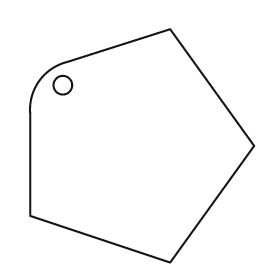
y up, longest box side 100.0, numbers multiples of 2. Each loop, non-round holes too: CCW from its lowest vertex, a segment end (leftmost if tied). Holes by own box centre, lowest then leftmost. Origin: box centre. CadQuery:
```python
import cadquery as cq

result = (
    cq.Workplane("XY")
    .moveTo(12.0, -50.0)
    .lineTo(48.0, 0.0)
    .lineTo(12.0, 50.0)
    .lineTo(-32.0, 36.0)
    .threePointArc((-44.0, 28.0), (-48.0, 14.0))
    .lineTo(-48.0, -30.0)
    .close()
    .moveTo(-34.0, 26.0)
    .circle(4.0)
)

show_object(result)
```